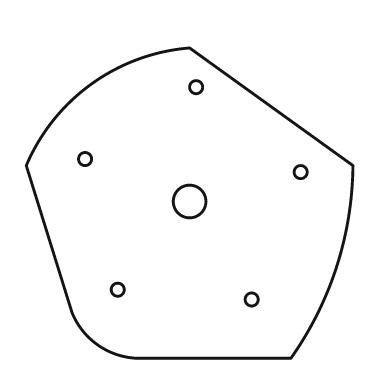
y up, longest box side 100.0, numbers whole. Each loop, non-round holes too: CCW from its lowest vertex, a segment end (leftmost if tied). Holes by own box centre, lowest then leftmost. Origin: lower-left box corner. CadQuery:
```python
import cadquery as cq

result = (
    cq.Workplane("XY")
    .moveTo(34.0, 0.0)
    .lineTo(81.0, 0.0)
    .threePointArc((95.0, 28.0), (100.0, 59.0))
    .lineTo(50.0, 95.0)
    .threePointArc((20.0, 84.0), (0.0, 59.0))
    .lineTo(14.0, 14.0)
    .threePointArc((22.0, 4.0), (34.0, 0.0))
    .close()
    .moveTo(69.0, 18.0)
    .circle(2.0)
    .moveTo(28.0, 21.0)
    .circle(2.0)
    .moveTo(50.0, 48.0)
    .circle(5.0)
    .moveTo(84.0, 57.0)
    .circle(2.0)
    .moveTo(18.0, 61.0)
    .circle(2.0)
    .moveTo(52.0, 83.0)
    .circle(2.0)
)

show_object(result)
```